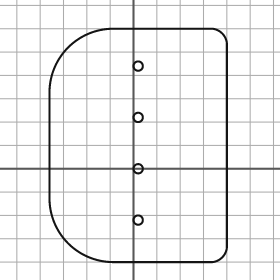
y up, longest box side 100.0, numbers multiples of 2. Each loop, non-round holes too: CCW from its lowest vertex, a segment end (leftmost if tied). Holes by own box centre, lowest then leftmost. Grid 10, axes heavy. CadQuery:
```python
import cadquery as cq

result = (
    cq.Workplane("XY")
    .moveTo(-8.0, -40.0)
    .lineTo(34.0, -40.0)
    .threePointArc((38.0, -38.0), (40.0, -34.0))
    .lineTo(40.0, 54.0)
    .threePointArc((38.0, 58.0), (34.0, 60.0))
    .lineTo(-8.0, 60.0)
    .threePointArc((-28.0, 52.0), (-36.0, 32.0))
    .lineTo(-36.0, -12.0)
    .threePointArc((-28.0, -32.0), (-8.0, -40.0))
    .close()
    .moveTo(2.0, -22.0)
    .circle(2.0)
    .moveTo(2.0, 0.0)
    .circle(2.0)
    .moveTo(2.0, 22.0)
    .circle(2.0)
    .moveTo(2.0, 44.0)
    .circle(2.0)
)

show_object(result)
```